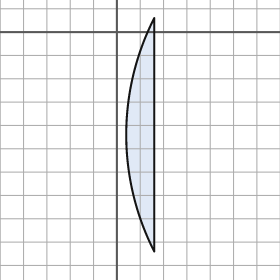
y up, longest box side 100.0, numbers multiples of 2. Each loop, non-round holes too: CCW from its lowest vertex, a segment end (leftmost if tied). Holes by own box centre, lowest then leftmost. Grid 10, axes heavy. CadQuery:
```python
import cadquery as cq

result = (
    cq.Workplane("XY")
    .moveTo(16.0, -94.0)
    .lineTo(16.0, 6.0)
    .threePointArc((4.0, -44.0), (16.0, -94.0))
    .close()
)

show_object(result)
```